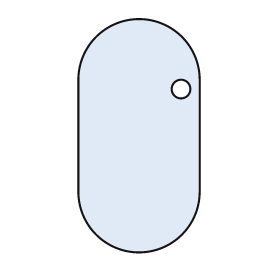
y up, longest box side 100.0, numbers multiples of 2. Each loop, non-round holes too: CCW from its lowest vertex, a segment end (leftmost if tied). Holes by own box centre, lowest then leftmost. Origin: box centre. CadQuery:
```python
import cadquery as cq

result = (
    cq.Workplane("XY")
    .moveTo(-26.0, -24.0)
    .threePointArc((0.0, -50.0), (26.0, -24.0))
    .lineTo(26.0, 24.0)
    .threePointArc((0.0, 50.0), (-26.0, 24.0))
    .close()
    .moveTo(18.0, 20.0)
    .circle(4.0)
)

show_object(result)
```